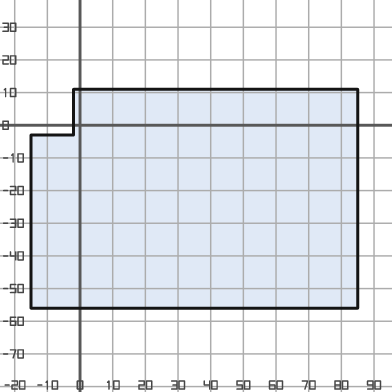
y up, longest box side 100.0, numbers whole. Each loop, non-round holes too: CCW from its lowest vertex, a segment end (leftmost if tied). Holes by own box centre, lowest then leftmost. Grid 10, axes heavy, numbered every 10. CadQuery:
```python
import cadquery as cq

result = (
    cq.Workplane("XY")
    .moveTo(-15.0, -56.0)
    .lineTo(85.0, -56.0)
    .lineTo(85.0, 11.0)
    .lineTo(-2.0, 11.0)
    .lineTo(-2.0, -3.0)
    .lineTo(-15.0, -3.0)
    .close()
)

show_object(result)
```